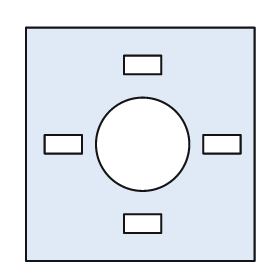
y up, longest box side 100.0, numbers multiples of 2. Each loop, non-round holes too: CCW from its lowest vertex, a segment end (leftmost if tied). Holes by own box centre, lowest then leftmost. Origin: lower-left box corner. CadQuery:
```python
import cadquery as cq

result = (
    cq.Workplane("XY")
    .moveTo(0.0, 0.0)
    .lineTo(98.0, 0.0)
    .lineTo(98.0, 100.0)
    .lineTo(0.0, 100.0)
    .close()
    .moveTo(42.0, 12.0)
    .lineTo(58.0, 12.0)
    .lineTo(58.0, 20.0)
    .lineTo(42.0, 20.0)
    .close()
    .moveTo(8.0, 46.0)
    .lineTo(24.0, 46.0)
    .lineTo(24.0, 54.0)
    .lineTo(8.0, 54.0)
    .close()
    .moveTo(50.0, 50.0)
    .circle(20.0)
    .moveTo(76.0, 46.0)
    .lineTo(92.0, 46.0)
    .lineTo(92.0, 54.0)
    .lineTo(76.0, 54.0)
    .close()
    .moveTo(42.0, 80.0)
    .lineTo(58.0, 80.0)
    .lineTo(58.0, 88.0)
    .lineTo(42.0, 88.0)
    .close()
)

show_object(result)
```